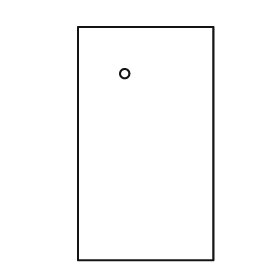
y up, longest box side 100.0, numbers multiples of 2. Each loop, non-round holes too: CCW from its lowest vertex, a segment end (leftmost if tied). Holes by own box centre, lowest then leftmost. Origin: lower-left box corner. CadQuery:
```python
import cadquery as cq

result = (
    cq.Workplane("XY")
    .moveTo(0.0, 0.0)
    .lineTo(58.0, 0.0)
    .lineTo(58.0, 100.0)
    .lineTo(0.0, 100.0)
    .close()
    .moveTo(20.0, 80.0)
    .circle(2.0)
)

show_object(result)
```